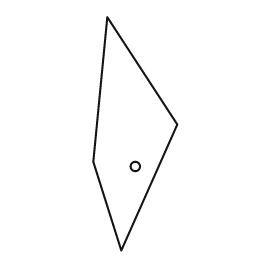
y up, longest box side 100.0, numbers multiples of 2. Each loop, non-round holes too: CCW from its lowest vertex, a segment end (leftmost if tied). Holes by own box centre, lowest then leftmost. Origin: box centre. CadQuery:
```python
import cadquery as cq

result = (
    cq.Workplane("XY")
    .moveTo(-6.0, -50.0)
    .lineTo(18.0, 4.0)
    .lineTo(-12.0, 50.0)
    .lineTo(-18.0, -12.0)
    .close()
    .moveTo(0.0, -14.0)
    .circle(2.0)
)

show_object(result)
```